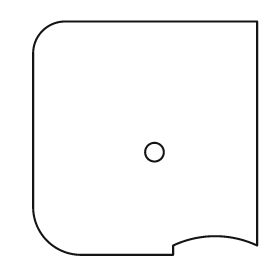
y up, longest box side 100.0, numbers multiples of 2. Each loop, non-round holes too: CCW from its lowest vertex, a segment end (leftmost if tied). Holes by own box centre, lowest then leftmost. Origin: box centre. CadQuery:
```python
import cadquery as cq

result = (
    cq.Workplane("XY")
    .moveTo(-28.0, -50.0)
    .lineTo(12.0, -50.0)
    .lineTo(12.0, -46.0)
    .threePointArc((30.0, -42.0), (48.0, -46.0))
    .lineTo(48.0, 50.0)
    .lineTo(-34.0, 50.0)
    .threePointArc((-44.0, 46.0), (-48.0, 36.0))
    .lineTo(-48.0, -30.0)
    .threePointArc((-42.0, -44.0), (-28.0, -50.0))
    .close()
    .moveTo(4.0, -6.0)
    .circle(4.0)
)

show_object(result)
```